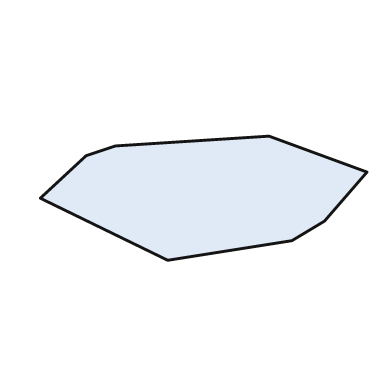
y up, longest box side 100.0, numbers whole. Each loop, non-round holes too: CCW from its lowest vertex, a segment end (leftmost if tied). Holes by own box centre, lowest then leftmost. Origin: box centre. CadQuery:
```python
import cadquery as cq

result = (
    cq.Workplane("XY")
    .moveTo(-11.0, -19.0)
    .lineTo(27.0, -13.0)
    .lineTo(37.0, -7.0)
    .lineTo(50.0, 8.0)
    .lineTo(20.0, 19.0)
    .lineTo(-27.0, 16.0)
    .lineTo(-36.0, 13.0)
    .lineTo(-50.0, 0.0)
    .close()
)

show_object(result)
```